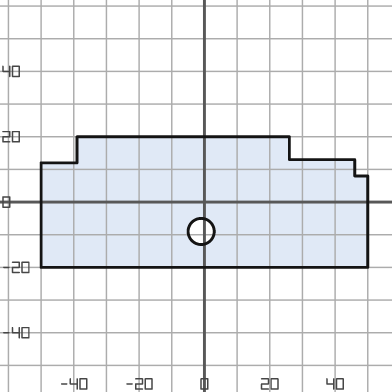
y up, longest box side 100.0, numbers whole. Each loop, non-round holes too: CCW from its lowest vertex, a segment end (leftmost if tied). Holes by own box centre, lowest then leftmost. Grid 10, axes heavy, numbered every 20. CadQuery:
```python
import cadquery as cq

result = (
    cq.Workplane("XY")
    .moveTo(-50.0, -20.0)
    .lineTo(50.0, -20.0)
    .lineTo(50.0, 8.0)
    .lineTo(46.0, 8.0)
    .lineTo(46.0, 13.0)
    .lineTo(26.0, 13.0)
    .lineTo(26.0, 20.0)
    .lineTo(-39.0, 20.0)
    .lineTo(-39.0, 12.0)
    .lineTo(-50.0, 12.0)
    .close()
    .moveTo(-1.0, -9.0)
    .circle(4.0)
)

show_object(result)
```